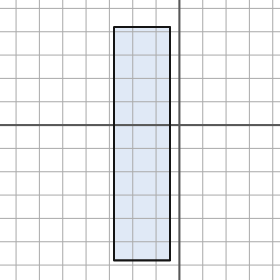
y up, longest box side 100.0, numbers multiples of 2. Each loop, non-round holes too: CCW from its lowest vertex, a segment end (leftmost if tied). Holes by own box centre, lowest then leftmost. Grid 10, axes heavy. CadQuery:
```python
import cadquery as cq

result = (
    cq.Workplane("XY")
    .moveTo(-28.0, -58.0)
    .lineTo(-4.0, -58.0)
    .lineTo(-4.0, 42.0)
    .lineTo(-28.0, 42.0)
    .close()
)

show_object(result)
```